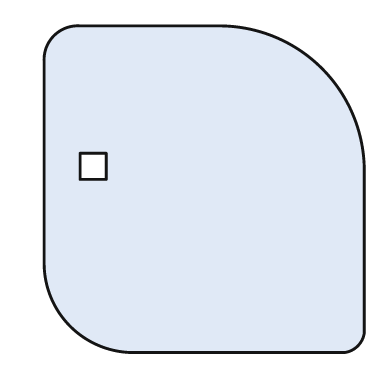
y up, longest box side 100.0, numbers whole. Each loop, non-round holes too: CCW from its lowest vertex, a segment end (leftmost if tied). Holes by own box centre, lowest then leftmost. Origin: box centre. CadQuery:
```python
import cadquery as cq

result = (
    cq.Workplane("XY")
    .moveTo(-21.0, -50.0)
    .lineTo(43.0, -50.0)
    .threePointArc((47.0, -48.0), (49.0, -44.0))
    .lineTo(49.0, 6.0)
    .threePointArc((36.0, 37.0), (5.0, 50.0))
    .lineTo(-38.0, 50.0)
    .threePointArc((-46.0, 47.0), (-49.0, 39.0))
    .lineTo(-49.0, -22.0)
    .threePointArc((-41.0, -42.0), (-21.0, -50.0))
    .close()
    .moveTo(-38.0, 3.0)
    .lineTo(-30.0, 3.0)
    .lineTo(-30.0, 11.0)
    .lineTo(-38.0, 11.0)
    .close()
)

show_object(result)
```